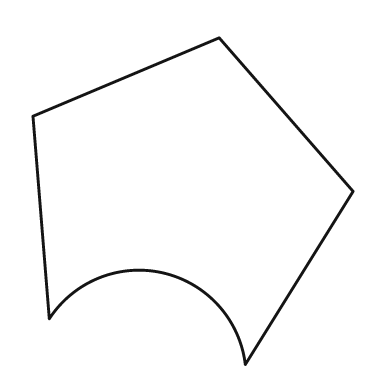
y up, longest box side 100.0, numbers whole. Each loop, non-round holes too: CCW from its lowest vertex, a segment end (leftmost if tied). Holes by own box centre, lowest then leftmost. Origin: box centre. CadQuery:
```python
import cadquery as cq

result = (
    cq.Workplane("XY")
    .moveTo(16.0, -50.0)
    .lineTo(49.0, 3.0)
    .lineTo(8.0, 50.0)
    .lineTo(-49.0, 26.0)
    .lineTo(-44.0, -36.0)
    .threePointArc((-9.0, -22.0), (16.0, -50.0))
    .close()
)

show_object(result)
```